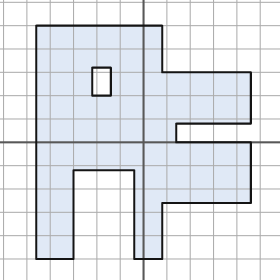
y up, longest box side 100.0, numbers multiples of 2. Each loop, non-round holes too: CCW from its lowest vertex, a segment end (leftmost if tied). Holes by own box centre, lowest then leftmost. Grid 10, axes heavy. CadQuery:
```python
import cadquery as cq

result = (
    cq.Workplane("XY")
    .moveTo(-46.0, -50.0)
    .lineTo(-30.0, -50.0)
    .lineTo(-30.0, -12.0)
    .lineTo(-4.0, -12.0)
    .lineTo(-4.0, -50.0)
    .lineTo(8.0, -50.0)
    .lineTo(8.0, -26.0)
    .lineTo(46.0, -26.0)
    .lineTo(46.0, 0.0)
    .lineTo(14.0, 0.0)
    .lineTo(14.0, 8.0)
    .lineTo(46.0, 8.0)
    .lineTo(46.0, 30.0)
    .lineTo(8.0, 30.0)
    .lineTo(8.0, 50.0)
    .lineTo(-46.0, 50.0)
    .close()
    .moveTo(-22.0, 20.0)
    .lineTo(-14.0, 20.0)
    .lineTo(-14.0, 32.0)
    .lineTo(-22.0, 32.0)
    .close()
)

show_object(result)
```